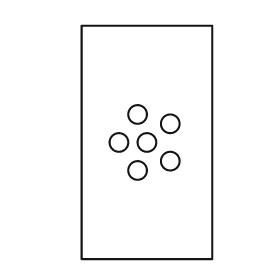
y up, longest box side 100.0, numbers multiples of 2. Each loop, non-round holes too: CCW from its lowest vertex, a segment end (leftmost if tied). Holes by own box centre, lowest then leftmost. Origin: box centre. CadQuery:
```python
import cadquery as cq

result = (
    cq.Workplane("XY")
    .moveTo(-28.0, -50.0)
    .lineTo(28.0, -50.0)
    .lineTo(28.0, 50.0)
    .lineTo(-28.0, 50.0)
    .close()
    .moveTo(-4.0, -12.0)
    .circle(4.0)
    .moveTo(10.0, -8.0)
    .circle(4.0)
    .moveTo(-12.0, 0.0)
    .circle(4.0)
    .moveTo(0.0, 0.0)
    .circle(4.0)
    .moveTo(10.0, 8.0)
    .circle(4.0)
    .moveTo(-4.0, 12.0)
    .circle(4.0)
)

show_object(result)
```